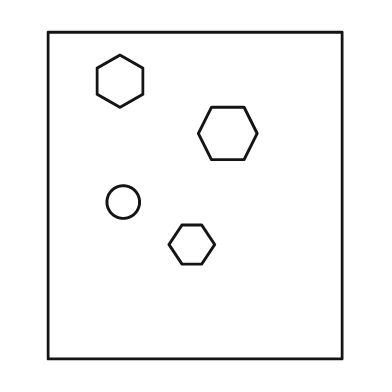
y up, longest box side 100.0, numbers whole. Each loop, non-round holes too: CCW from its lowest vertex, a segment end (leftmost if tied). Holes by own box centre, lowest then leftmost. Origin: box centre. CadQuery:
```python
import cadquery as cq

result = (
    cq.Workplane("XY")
    .moveTo(-45.0, -50.0)
    .lineTo(45.0, -50.0)
    .lineTo(45.0, 50.0)
    .lineTo(-45.0, 50.0)
    .close()
    .moveTo(-4.0, -21.0)
    .lineTo(2.0, -21.0)
    .lineTo(6.0, -15.0)
    .lineTo(2.0, -9.0)
    .lineTo(-4.0, -9.0)
    .lineTo(-8.0, -15.0)
    .close()
    .moveTo(-22.0, -2.0)
    .circle(5.0)
    .moveTo(5.0, 11.0)
    .lineTo(15.0, 11.0)
    .lineTo(19.0, 19.0)
    .lineTo(15.0, 27.0)
    .lineTo(5.0, 27.0)
    .lineTo(1.0, 19.0)
    .close()
    .moveTo(-23.0, 27.0)
    .lineTo(-16.0, 31.0)
    .lineTo(-16.0, 39.0)
    .lineTo(-23.0, 43.0)
    .lineTo(-30.0, 39.0)
    .lineTo(-30.0, 31.0)
    .close()
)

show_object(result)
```